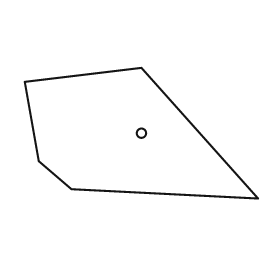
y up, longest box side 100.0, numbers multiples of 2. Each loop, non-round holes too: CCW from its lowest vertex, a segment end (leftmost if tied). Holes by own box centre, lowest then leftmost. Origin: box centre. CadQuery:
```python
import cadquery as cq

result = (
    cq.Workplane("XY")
    .moveTo(50.0, -28.0)
    .lineTo(0.0, 28.0)
    .lineTo(-50.0, 22.0)
    .lineTo(-44.0, -12.0)
    .lineTo(-30.0, -24.0)
    .close()
    .moveTo(0.0, 0.0)
    .circle(2.0)
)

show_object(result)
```